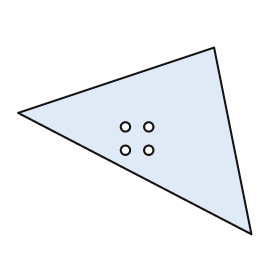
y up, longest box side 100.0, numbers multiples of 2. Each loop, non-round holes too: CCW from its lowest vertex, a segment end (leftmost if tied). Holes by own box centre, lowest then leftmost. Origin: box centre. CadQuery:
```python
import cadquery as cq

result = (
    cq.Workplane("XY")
    .moveTo(50.0, -40.0)
    .lineTo(34.0, 40.0)
    .lineTo(-50.0, 12.0)
    .close()
    .moveTo(-4.0, -4.0)
    .circle(2.0)
    .moveTo(6.0, -4.0)
    .circle(2.0)
    .moveTo(-4.0, 6.0)
    .circle(2.0)
    .moveTo(6.0, 6.0)
    .circle(2.0)
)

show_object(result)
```